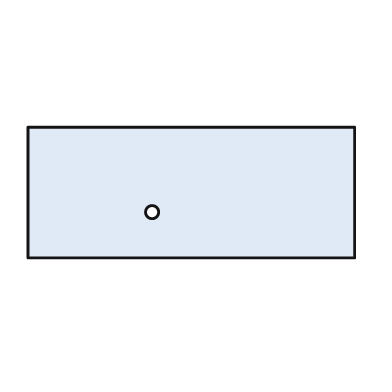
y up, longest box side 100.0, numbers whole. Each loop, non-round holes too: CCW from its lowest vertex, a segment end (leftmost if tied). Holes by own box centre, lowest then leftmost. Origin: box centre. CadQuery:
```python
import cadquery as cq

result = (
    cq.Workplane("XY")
    .moveTo(-50.0, -20.0)
    .lineTo(50.0, -20.0)
    .lineTo(50.0, 20.0)
    .lineTo(-50.0, 20.0)
    .close()
    .moveTo(-12.0, -6.0)
    .circle(2.0)
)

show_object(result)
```